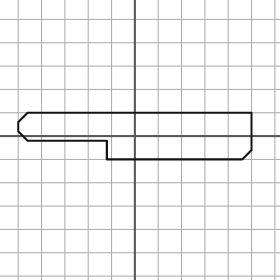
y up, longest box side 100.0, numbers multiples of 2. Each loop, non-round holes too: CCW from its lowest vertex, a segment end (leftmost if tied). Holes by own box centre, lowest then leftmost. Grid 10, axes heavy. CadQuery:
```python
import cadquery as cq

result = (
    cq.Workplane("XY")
    .moveTo(-12.0, -10.0)
    .lineTo(46.0, -10.0)
    .lineTo(50.0, -6.0)
    .lineTo(50.0, 10.0)
    .lineTo(-46.0, 10.0)
    .lineTo(-50.0, 6.0)
    .lineTo(-50.0, 2.0)
    .lineTo(-46.0, -2.0)
    .lineTo(-12.0, -2.0)
    .close()
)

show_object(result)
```